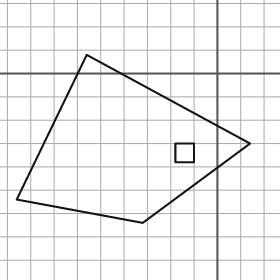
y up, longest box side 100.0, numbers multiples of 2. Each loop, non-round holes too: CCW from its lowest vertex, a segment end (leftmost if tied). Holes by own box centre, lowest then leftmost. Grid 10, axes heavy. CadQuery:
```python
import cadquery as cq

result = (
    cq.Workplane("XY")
    .moveTo(-32.0, -64.0)
    .lineTo(14.0, -30.0)
    .lineTo(-56.0, 8.0)
    .lineTo(-86.0, -54.0)
    .close()
    .moveTo(-18.0, -38.0)
    .lineTo(-10.0, -38.0)
    .lineTo(-10.0, -30.0)
    .lineTo(-18.0, -30.0)
    .close()
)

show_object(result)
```